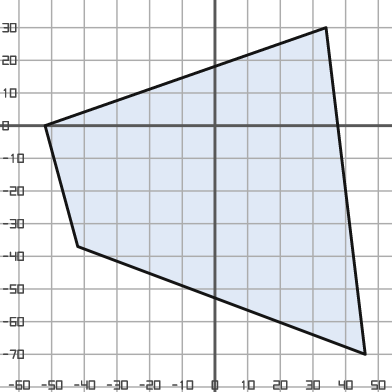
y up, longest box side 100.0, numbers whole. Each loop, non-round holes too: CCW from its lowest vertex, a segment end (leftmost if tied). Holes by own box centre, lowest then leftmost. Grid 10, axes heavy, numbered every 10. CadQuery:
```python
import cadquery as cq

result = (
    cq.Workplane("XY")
    .moveTo(46.0, -70.0)
    .lineTo(34.0, 30.0)
    .lineTo(-52.0, 0.0)
    .lineTo(-42.0, -37.0)
    .close()
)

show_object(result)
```